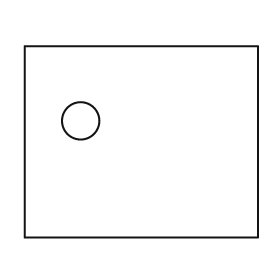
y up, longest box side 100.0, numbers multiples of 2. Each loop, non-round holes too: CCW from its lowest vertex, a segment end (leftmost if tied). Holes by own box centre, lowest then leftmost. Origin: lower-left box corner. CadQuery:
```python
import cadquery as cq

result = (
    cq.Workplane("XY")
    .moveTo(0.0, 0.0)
    .lineTo(100.0, 0.0)
    .lineTo(100.0, 82.0)
    .lineTo(0.0, 82.0)
    .close()
    .moveTo(24.0, 50.0)
    .circle(8.0)
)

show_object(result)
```